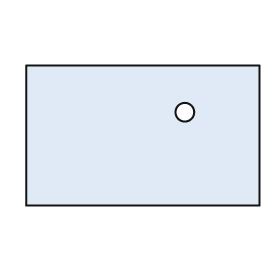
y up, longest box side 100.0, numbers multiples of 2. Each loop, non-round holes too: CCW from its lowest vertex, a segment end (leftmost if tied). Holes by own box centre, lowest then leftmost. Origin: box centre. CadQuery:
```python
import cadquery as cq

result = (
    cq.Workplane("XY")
    .moveTo(-50.0, -30.0)
    .lineTo(50.0, -30.0)
    .lineTo(50.0, 30.0)
    .lineTo(-50.0, 30.0)
    .close()
    .moveTo(18.0, 10.0)
    .circle(4.0)
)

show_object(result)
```